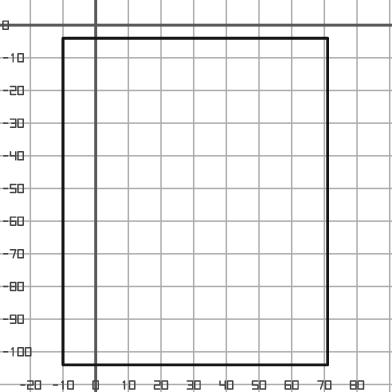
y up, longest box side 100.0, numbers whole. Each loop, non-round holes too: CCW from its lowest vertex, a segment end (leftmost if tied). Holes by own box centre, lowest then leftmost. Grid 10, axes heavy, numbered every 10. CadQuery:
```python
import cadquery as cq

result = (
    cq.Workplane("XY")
    .moveTo(-10.0, -104.0)
    .lineTo(71.0, -104.0)
    .lineTo(71.0, -4.0)
    .lineTo(-10.0, -4.0)
    .close()
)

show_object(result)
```